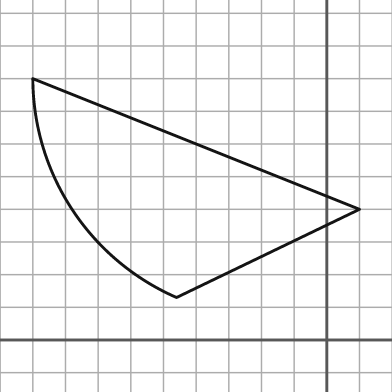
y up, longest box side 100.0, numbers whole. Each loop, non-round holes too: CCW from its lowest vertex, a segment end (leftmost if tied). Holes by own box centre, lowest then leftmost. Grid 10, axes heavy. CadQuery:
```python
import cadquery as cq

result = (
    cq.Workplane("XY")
    .moveTo(-46.0, 13.0)
    .lineTo(10.0, 40.0)
    .lineTo(-90.0, 80.0)
    .threePointArc((-78.0, 40.0), (-46.0, 13.0))
    .close()
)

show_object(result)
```